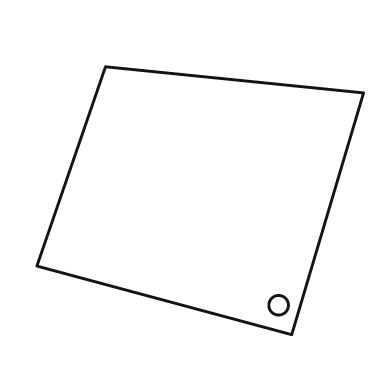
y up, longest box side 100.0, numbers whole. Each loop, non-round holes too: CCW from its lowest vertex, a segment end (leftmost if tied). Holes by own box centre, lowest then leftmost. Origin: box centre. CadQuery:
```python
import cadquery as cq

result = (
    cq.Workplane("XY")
    .moveTo(28.0, -41.0)
    .lineTo(50.0, 33.0)
    .lineTo(-29.0, 41.0)
    .lineTo(-50.0, -20.0)
    .close()
    .moveTo(24.0, -32.0)
    .circle(3.0)
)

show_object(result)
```